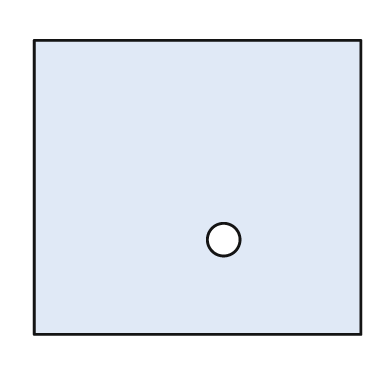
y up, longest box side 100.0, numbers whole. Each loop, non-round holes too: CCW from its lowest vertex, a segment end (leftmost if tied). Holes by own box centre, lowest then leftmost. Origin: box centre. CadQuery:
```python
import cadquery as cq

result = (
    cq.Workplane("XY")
    .moveTo(-50.0, -45.0)
    .lineTo(50.0, -45.0)
    .lineTo(50.0, 45.0)
    .lineTo(-50.0, 45.0)
    .close()
    .moveTo(8.0, -16.0)
    .circle(5.0)
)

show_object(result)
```